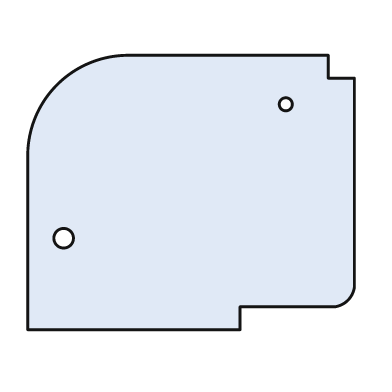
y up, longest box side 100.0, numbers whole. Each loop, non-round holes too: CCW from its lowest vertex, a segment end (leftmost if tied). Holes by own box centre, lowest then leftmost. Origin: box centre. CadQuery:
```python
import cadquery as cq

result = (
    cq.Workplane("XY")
    .moveTo(-50.0, -42.0)
    .lineTo(15.0, -42.0)
    .lineTo(15.0, -35.0)
    .lineTo(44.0, -35.0)
    .threePointArc((48.0, -33.0), (50.0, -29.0))
    .lineTo(50.0, 35.0)
    .lineTo(42.0, 35.0)
    .lineTo(42.0, 42.0)
    .lineTo(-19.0, 42.0)
    .threePointArc((-41.0, 33.0), (-50.0, 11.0))
    .close()
    .moveTo(-39.0, -14.0)
    .circle(3.0)
    .moveTo(29.0, 27.0)
    .circle(2.0)
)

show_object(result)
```